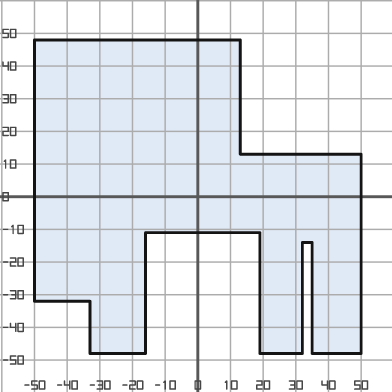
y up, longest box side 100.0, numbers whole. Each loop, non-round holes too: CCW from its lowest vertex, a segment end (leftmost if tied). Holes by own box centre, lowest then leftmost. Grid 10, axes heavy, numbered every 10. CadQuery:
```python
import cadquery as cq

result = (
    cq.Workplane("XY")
    .moveTo(-33.0, -48.0)
    .lineTo(-16.0, -48.0)
    .lineTo(-16.0, -11.0)
    .lineTo(19.0, -11.0)
    .lineTo(19.0, -48.0)
    .lineTo(32.0, -48.0)
    .lineTo(32.0, -14.0)
    .lineTo(35.0, -14.0)
    .lineTo(35.0, -48.0)
    .lineTo(50.0, -48.0)
    .lineTo(50.0, 13.0)
    .lineTo(13.0, 13.0)
    .lineTo(13.0, 48.0)
    .lineTo(-50.0, 48.0)
    .lineTo(-50.0, -32.0)
    .lineTo(-33.0, -32.0)
    .close()
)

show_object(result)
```